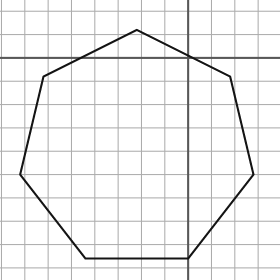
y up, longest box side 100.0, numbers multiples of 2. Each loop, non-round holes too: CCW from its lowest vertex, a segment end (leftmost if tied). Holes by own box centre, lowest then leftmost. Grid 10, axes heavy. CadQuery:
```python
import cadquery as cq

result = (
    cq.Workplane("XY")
    .moveTo(-44.0, -86.0)
    .lineTo(0.0, -86.0)
    .lineTo(28.0, -50.0)
    .lineTo(18.0, -8.0)
    .lineTo(-22.0, 12.0)
    .lineTo(-62.0, -8.0)
    .lineTo(-72.0, -50.0)
    .close()
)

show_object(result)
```